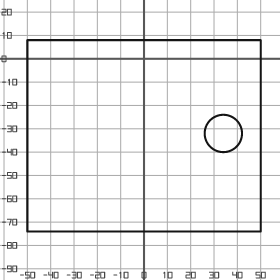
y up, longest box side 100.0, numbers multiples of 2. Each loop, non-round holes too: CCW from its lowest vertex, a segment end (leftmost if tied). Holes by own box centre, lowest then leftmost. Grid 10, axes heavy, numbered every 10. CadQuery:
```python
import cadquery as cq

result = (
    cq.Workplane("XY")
    .moveTo(-50.0, -74.0)
    .lineTo(50.0, -74.0)
    .lineTo(50.0, 8.0)
    .lineTo(-50.0, 8.0)
    .close()
    .moveTo(34.0, -32.0)
    .circle(8.0)
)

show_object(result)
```